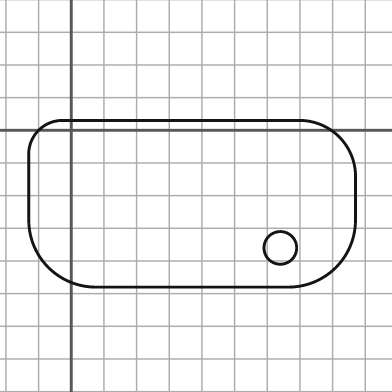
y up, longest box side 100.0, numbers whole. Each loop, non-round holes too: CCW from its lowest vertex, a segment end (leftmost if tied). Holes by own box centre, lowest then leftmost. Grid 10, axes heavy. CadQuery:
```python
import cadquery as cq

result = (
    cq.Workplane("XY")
    .moveTo(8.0, -48.0)
    .lineTo(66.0, -48.0)
    .threePointArc((81.0, -42.0), (87.0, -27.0))
    .lineTo(87.0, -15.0)
    .threePointArc((82.0, -2.0), (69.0, 3.0))
    .lineTo(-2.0, 3.0)
    .threePointArc((-10.0, 0.0), (-13.0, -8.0))
    .lineTo(-13.0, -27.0)
    .threePointArc((-7.0, -42.0), (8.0, -48.0))
    .close()
    .moveTo(64.0, -36.0)
    .circle(5.0)
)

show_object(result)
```